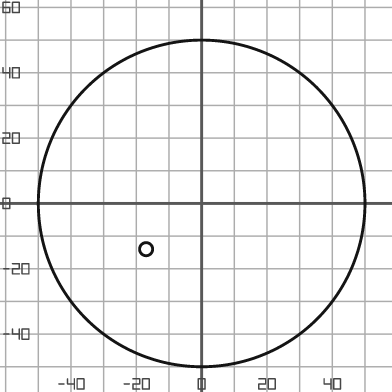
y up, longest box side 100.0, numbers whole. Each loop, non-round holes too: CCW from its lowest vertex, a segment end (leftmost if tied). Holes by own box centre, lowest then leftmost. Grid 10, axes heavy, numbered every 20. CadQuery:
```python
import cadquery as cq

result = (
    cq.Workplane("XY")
    .moveTo(0.0, 0.0)
    .circle(50.0)
    .moveTo(-17.0, -14.0)
    .circle(2.0)
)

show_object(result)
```